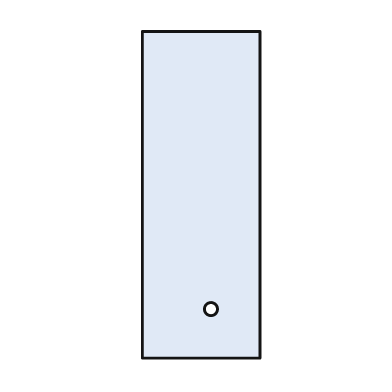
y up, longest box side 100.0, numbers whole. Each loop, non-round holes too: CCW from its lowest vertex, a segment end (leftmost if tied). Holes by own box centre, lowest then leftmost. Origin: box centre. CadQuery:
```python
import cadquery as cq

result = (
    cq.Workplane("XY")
    .moveTo(-18.0, -50.0)
    .lineTo(18.0, -50.0)
    .lineTo(18.0, 50.0)
    .lineTo(-18.0, 50.0)
    .close()
    .moveTo(3.0, -35.0)
    .circle(2.0)
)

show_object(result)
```